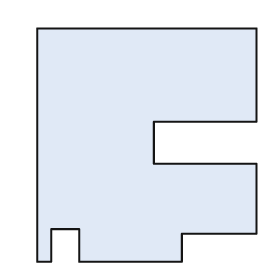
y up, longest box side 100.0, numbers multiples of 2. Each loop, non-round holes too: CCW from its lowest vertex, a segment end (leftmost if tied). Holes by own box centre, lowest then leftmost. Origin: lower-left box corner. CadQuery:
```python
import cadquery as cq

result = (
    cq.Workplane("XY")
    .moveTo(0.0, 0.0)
    .lineTo(6.0, 0.0)
    .lineTo(6.0, 14.0)
    .lineTo(18.0, 14.0)
    .lineTo(18.0, 0.0)
    .lineTo(62.0, 0.0)
    .lineTo(62.0, 12.0)
    .lineTo(94.0, 12.0)
    .lineTo(94.0, 42.0)
    .lineTo(50.0, 42.0)
    .lineTo(50.0, 60.0)
    .lineTo(94.0, 60.0)
    .lineTo(94.0, 100.0)
    .lineTo(0.0, 100.0)
    .close()
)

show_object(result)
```